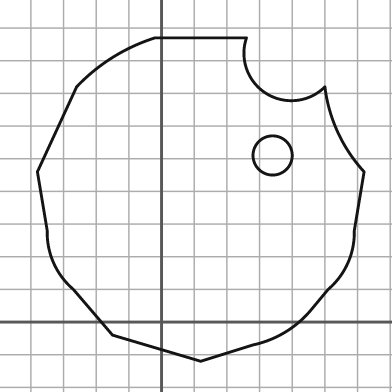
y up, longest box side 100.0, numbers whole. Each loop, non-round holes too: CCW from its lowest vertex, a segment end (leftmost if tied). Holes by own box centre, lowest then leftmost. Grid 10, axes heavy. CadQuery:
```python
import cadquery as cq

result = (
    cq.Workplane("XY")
    .moveTo(12.0, -12.0)
    .lineTo(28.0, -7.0)
    .threePointArc((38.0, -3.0), (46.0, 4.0))
    .lineTo(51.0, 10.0)
    .threePointArc((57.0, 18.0), (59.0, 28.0))
    .lineTo(62.0, 46.0)
    .threePointArc((54.0, 58.0), (50.0, 72.0))
    .threePointArc((32.0, 70.0), (26.0, 87.0))
    .lineTo(-2.0, 87.0)
    .threePointArc((-15.0, 81.0), (-26.0, 72.0))
    .lineTo(-38.0, 46.0)
    .lineTo(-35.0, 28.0)
    .threePointArc((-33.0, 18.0), (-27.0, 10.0))
    .lineTo(-15.0, -4.0)
    .close()
    .moveTo(34.0, 51.0)
    .circle(6.0)
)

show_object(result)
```